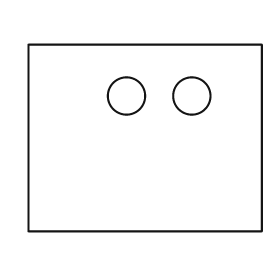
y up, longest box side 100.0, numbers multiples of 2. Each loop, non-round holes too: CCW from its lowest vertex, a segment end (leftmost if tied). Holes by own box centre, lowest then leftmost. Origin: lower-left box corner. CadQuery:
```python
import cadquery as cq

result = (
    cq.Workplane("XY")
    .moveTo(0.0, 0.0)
    .lineTo(100.0, 0.0)
    .lineTo(100.0, 80.0)
    .lineTo(0.0, 80.0)
    .close()
    .moveTo(42.0, 58.0)
    .circle(8.0)
    .moveTo(70.0, 58.0)
    .circle(8.0)
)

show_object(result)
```